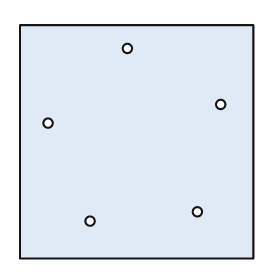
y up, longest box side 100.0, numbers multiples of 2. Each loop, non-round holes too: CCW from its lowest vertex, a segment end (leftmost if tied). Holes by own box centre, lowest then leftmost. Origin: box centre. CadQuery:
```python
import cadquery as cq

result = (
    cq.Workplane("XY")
    .moveTo(-50.0, -50.0)
    .lineTo(50.0, -50.0)
    .lineTo(50.0, 50.0)
    .lineTo(-50.0, 50.0)
    .close()
    .moveTo(-20.0, -34.0)
    .circle(2.0)
    .moveTo(26.0, -30.0)
    .circle(2.0)
    .moveTo(-38.0, 8.0)
    .circle(2.0)
    .moveTo(36.0, 16.0)
    .circle(2.0)
    .moveTo(-4.0, 40.0)
    .circle(2.0)
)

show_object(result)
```